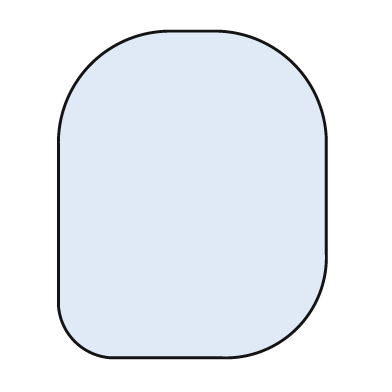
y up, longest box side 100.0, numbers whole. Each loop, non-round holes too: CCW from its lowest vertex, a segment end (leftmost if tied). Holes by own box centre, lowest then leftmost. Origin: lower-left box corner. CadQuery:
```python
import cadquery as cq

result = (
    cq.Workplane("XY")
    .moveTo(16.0, 0.0)
    .lineTo(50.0, 0.0)
    .threePointArc((73.0, 9.0), (82.0, 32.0))
    .lineTo(82.0, 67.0)
    .threePointArc((72.0, 90.0), (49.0, 100.0))
    .lineTo(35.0, 100.0)
    .threePointArc((10.0, 90.0), (0.0, 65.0))
    .lineTo(0.0, 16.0)
    .threePointArc((5.0, 5.0), (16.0, 0.0))
    .close()
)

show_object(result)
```